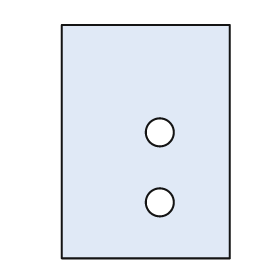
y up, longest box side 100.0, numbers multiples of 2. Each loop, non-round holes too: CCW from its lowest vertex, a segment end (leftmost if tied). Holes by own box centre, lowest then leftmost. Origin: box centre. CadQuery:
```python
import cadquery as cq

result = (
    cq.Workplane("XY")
    .moveTo(-36.0, -50.0)
    .lineTo(36.0, -50.0)
    .lineTo(36.0, 50.0)
    .lineTo(-36.0, 50.0)
    .close()
    .moveTo(6.0, -26.0)
    .circle(6.0)
    .moveTo(6.0, 4.0)
    .circle(6.0)
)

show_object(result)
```